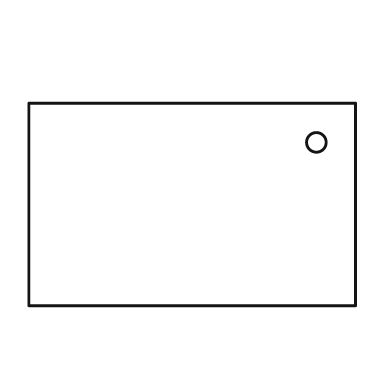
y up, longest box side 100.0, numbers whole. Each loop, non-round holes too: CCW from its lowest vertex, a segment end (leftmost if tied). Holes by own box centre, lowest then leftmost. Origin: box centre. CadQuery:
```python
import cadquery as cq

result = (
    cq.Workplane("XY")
    .moveTo(-50.0, -31.0)
    .lineTo(50.0, -31.0)
    .lineTo(50.0, 31.0)
    .lineTo(-50.0, 31.0)
    .close()
    .moveTo(38.0, 19.0)
    .circle(3.0)
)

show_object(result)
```